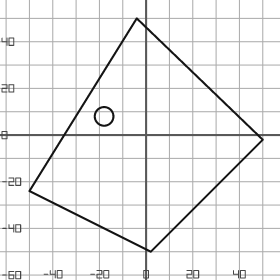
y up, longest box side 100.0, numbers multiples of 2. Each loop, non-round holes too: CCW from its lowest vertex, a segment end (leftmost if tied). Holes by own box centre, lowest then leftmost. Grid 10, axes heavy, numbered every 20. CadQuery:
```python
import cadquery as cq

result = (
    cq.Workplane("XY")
    .moveTo(2.0, -50.0)
    .lineTo(50.0, -2.0)
    .lineTo(-4.0, 50.0)
    .lineTo(-50.0, -24.0)
    .close()
    .moveTo(-18.0, 8.0)
    .circle(4.0)
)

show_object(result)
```